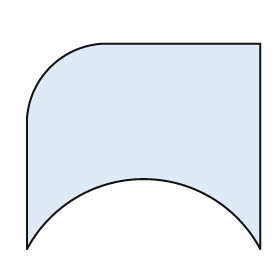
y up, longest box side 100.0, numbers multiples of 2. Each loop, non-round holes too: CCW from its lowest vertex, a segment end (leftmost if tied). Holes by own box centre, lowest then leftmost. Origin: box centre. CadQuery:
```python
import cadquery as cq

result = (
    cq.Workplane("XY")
    .moveTo(-50.0, -44.0)
    .threePointArc((0.0, -14.0), (50.0, -44.0))
    .lineTo(50.0, 44.0)
    .lineTo(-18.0, 44.0)
    .threePointArc((-40.0, 34.0), (-50.0, 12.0))
    .close()
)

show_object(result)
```